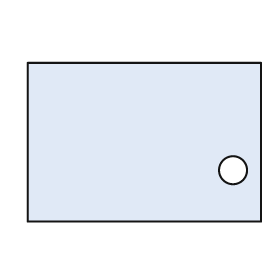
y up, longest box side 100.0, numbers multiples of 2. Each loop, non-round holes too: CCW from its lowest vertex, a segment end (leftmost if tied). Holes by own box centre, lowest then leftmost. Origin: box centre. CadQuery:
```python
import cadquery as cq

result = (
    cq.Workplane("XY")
    .moveTo(-50.0, -34.0)
    .lineTo(50.0, -34.0)
    .lineTo(50.0, 34.0)
    .lineTo(-50.0, 34.0)
    .close()
    .moveTo(38.0, -12.0)
    .circle(6.0)
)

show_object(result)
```